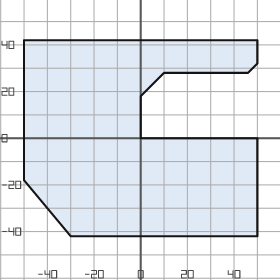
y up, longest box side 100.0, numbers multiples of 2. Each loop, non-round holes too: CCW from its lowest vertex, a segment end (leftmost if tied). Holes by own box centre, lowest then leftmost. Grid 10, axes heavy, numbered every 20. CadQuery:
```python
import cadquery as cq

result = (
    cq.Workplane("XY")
    .moveTo(-30.0, -42.0)
    .lineTo(50.0, -42.0)
    .lineTo(50.0, 0.0)
    .lineTo(0.0, 0.0)
    .lineTo(0.0, 18.0)
    .lineTo(10.0, 28.0)
    .lineTo(46.0, 28.0)
    .lineTo(50.0, 32.0)
    .lineTo(50.0, 42.0)
    .lineTo(-50.0, 42.0)
    .lineTo(-50.0, -18.0)
    .close()
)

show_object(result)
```